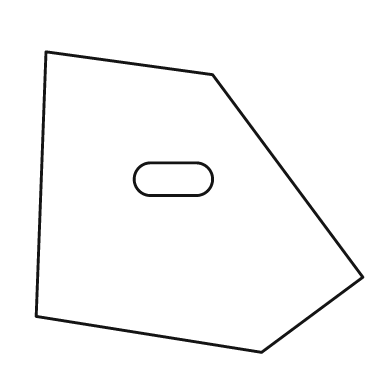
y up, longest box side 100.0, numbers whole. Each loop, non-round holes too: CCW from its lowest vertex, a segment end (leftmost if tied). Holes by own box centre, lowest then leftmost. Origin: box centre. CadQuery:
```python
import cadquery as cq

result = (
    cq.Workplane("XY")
    .moveTo(19.0, -46.0)
    .lineTo(50.0, -23.0)
    .lineTo(4.0, 39.0)
    .lineTo(-47.0, 46.0)
    .lineTo(-50.0, -35.0)
    .close()
    .moveTo(-15.0, 2.0)
    .lineTo(-1.0, 2.0)
    .threePointArc((4.0, 7.0), (-1.0, 12.0))
    .lineTo(-15.0, 12.0)
    .threePointArc((-20.0, 7.0), (-15.0, 2.0))
    .close()
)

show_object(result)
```